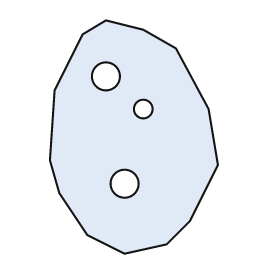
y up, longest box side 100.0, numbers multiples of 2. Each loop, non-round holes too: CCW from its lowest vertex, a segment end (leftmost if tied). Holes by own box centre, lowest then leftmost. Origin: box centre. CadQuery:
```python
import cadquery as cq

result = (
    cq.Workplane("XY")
    .moveTo(-4.0, -50.0)
    .lineTo(14.0, -46.0)
    .lineTo(24.0, -36.0)
    .lineTo(36.0, -12.0)
    .lineTo(32.0, 12.0)
    .lineTo(18.0, 38.0)
    .lineTo(4.0, 46.0)
    .lineTo(-12.0, 50.0)
    .lineTo(-22.0, 44.0)
    .lineTo(-34.0, 20.0)
    .lineTo(-36.0, -10.0)
    .lineTo(-32.0, -24.0)
    .lineTo(-20.0, -42.0)
    .close()
    .moveTo(-4.0, -20.0)
    .circle(6.0)
    .moveTo(4.0, 12.0)
    .circle(4.0)
    .moveTo(-12.0, 26.0)
    .circle(6.0)
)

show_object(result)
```